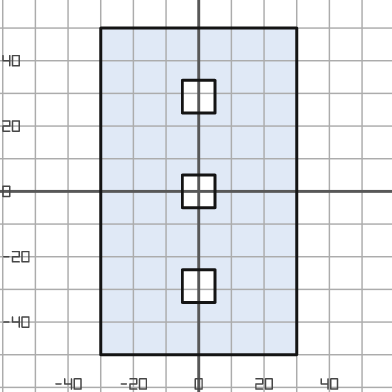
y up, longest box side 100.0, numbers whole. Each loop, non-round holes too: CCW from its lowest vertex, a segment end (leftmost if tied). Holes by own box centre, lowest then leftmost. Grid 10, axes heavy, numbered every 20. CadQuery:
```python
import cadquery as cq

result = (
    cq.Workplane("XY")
    .moveTo(-30.0, -50.0)
    .lineTo(30.0, -50.0)
    .lineTo(30.0, 50.0)
    .lineTo(-30.0, 50.0)
    .close()
    .moveTo(-5.0, -34.0)
    .lineTo(5.0, -34.0)
    .lineTo(5.0, -24.0)
    .lineTo(-5.0, -24.0)
    .close()
    .moveTo(-5.0, -5.0)
    .lineTo(5.0, -5.0)
    .lineTo(5.0, 5.0)
    .lineTo(-5.0, 5.0)
    .close()
    .moveTo(-5.0, 24.0)
    .lineTo(5.0, 24.0)
    .lineTo(5.0, 34.0)
    .lineTo(-5.0, 34.0)
    .close()
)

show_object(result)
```